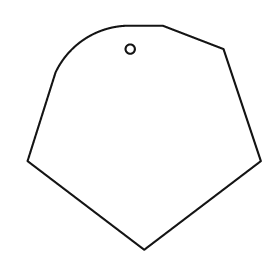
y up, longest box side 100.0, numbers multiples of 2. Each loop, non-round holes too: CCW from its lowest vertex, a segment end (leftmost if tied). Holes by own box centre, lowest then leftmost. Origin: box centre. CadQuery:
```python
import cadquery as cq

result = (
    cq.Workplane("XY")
    .moveTo(0.0, -48.0)
    .lineTo(50.0, -10.0)
    .lineTo(34.0, 38.0)
    .lineTo(8.0, 48.0)
    .lineTo(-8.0, 48.0)
    .threePointArc((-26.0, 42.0), (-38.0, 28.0))
    .lineTo(-50.0, -10.0)
    .close()
    .moveTo(-6.0, 38.0)
    .circle(2.0)
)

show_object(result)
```